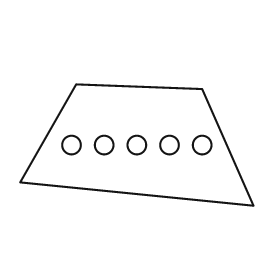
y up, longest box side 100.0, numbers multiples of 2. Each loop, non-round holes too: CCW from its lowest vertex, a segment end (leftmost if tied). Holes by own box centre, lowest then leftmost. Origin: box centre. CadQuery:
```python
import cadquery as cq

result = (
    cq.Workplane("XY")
    .moveTo(50.0, -26.0)
    .lineTo(28.0, 24.0)
    .lineTo(-26.0, 26.0)
    .lineTo(-50.0, -16.0)
    .close()
    .moveTo(-28.0, 0.0)
    .circle(4.0)
    .moveTo(-14.0, 0.0)
    .circle(4.0)
    .moveTo(0.0, 0.0)
    .circle(4.0)
    .moveTo(14.0, 0.0)
    .circle(4.0)
    .moveTo(28.0, 0.0)
    .circle(4.0)
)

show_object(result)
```